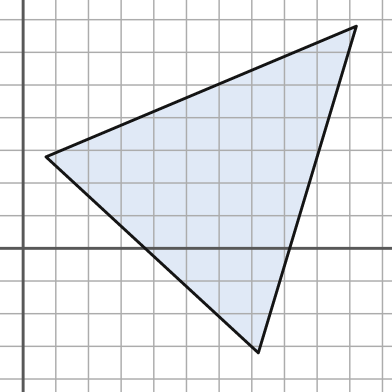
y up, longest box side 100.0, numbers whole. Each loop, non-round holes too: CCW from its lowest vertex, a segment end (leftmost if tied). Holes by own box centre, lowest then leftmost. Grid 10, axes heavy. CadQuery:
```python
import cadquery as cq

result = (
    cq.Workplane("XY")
    .moveTo(72.0, -32.0)
    .lineTo(102.0, 68.0)
    .lineTo(7.0, 28.0)
    .close()
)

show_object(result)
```